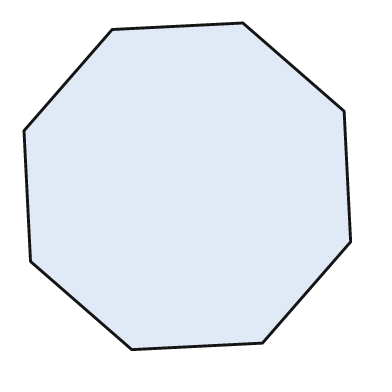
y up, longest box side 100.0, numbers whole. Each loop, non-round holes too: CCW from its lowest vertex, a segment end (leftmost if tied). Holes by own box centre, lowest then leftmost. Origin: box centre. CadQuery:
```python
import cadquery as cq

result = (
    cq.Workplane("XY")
    .moveTo(-17.0, -50.0)
    .lineTo(23.0, -48.0)
    .lineTo(50.0, -17.0)
    .lineTo(48.0, 23.0)
    .lineTo(17.0, 50.0)
    .lineTo(-23.0, 48.0)
    .lineTo(-50.0, 17.0)
    .lineTo(-48.0, -23.0)
    .close()
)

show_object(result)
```